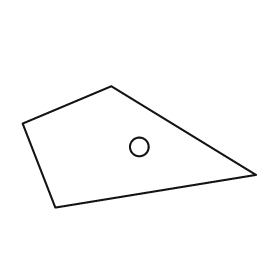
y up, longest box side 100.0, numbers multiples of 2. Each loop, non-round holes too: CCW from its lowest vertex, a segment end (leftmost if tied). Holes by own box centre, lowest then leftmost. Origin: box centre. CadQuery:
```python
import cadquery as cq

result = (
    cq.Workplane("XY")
    .moveTo(-36.0, -26.0)
    .lineTo(50.0, -12.0)
    .lineTo(-12.0, 26.0)
    .lineTo(-50.0, 10.0)
    .close()
    .moveTo(0.0, 0.0)
    .circle(4.0)
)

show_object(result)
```